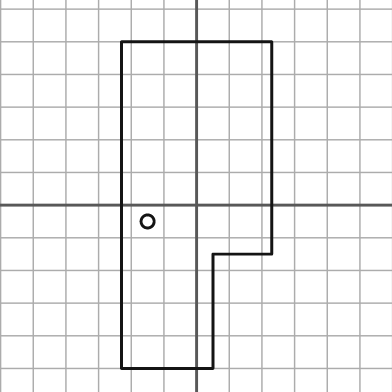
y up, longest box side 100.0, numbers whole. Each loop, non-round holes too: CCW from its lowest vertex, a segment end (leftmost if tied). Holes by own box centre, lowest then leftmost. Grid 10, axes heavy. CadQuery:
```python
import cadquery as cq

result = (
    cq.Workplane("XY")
    .moveTo(-23.0, -50.0)
    .lineTo(5.0, -50.0)
    .lineTo(5.0, -15.0)
    .lineTo(23.0, -15.0)
    .lineTo(23.0, 50.0)
    .lineTo(-23.0, 50.0)
    .close()
    .moveTo(-15.0, -5.0)
    .circle(2.0)
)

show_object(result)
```